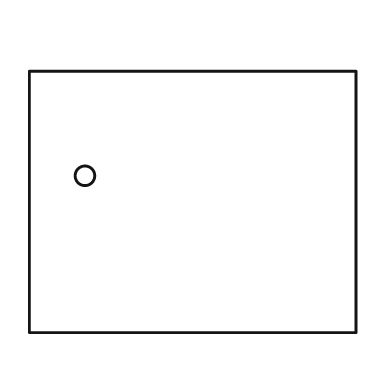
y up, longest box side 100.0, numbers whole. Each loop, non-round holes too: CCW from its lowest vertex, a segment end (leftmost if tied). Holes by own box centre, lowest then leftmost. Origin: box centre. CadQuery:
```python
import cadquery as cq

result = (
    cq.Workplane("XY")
    .moveTo(-50.0, -40.0)
    .lineTo(50.0, -40.0)
    .lineTo(50.0, 40.0)
    .lineTo(-50.0, 40.0)
    .close()
    .moveTo(-33.0, 8.0)
    .circle(3.0)
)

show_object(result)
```